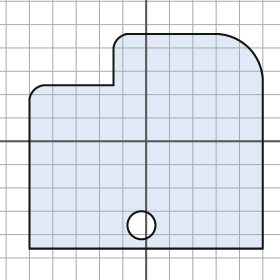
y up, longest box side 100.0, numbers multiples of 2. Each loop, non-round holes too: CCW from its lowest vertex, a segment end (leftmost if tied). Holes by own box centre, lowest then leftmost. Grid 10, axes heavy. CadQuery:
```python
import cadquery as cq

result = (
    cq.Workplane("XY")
    .moveTo(-50.0, -46.0)
    .lineTo(50.0, -46.0)
    .lineTo(50.0, 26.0)
    .threePointArc((44.0, 40.0), (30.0, 46.0))
    .lineTo(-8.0, 46.0)
    .threePointArc((-12.0, 44.0), (-14.0, 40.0))
    .lineTo(-14.0, 24.0)
    .lineTo(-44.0, 24.0)
    .threePointArc((-48.0, 22.0), (-50.0, 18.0))
    .close()
    .moveTo(-2.0, -36.0)
    .circle(6.0)
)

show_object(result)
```